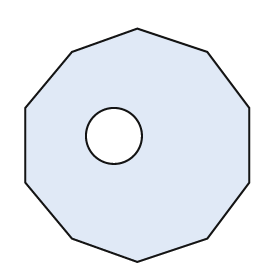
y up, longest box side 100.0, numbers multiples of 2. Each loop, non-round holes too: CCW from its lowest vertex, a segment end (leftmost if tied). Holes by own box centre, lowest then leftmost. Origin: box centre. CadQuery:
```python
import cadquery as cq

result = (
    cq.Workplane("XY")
    .moveTo(0.0, -50.0)
    .lineTo(30.0, -40.0)
    .lineTo(48.0, -16.0)
    .lineTo(48.0, 16.0)
    .lineTo(30.0, 40.0)
    .lineTo(0.0, 50.0)
    .lineTo(-28.0, 40.0)
    .lineTo(-48.0, 16.0)
    .lineTo(-48.0, -16.0)
    .lineTo(-28.0, -40.0)
    .close()
    .moveTo(-10.0, 4.0)
    .circle(12.0)
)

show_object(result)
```